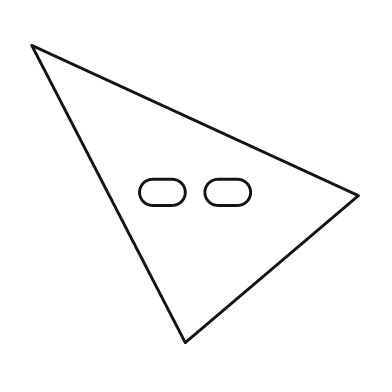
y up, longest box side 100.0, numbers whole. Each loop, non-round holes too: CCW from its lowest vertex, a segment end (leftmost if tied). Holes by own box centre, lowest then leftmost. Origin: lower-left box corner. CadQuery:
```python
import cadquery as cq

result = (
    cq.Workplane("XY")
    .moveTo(47.0, 0.0)
    .lineTo(100.0, 45.0)
    .lineTo(0.0, 91.0)
    .close()
    .moveTo(37.0, 42.0)
    .lineTo(43.0, 42.0)
    .threePointArc((47.0, 46.0), (43.0, 50.0))
    .lineTo(37.0, 50.0)
    .threePointArc((33.0, 46.0), (37.0, 42.0))
    .close()
    .moveTo(57.0, 42.0)
    .lineTo(63.0, 42.0)
    .threePointArc((67.0, 46.0), (63.0, 50.0))
    .lineTo(57.0, 50.0)
    .threePointArc((53.0, 46.0), (57.0, 42.0))
    .close()
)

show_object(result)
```